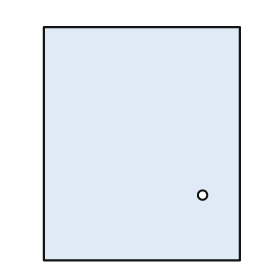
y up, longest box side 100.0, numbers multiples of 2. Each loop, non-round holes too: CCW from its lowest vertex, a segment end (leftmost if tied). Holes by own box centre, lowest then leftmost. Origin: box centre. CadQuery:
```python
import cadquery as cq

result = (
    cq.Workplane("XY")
    .moveTo(-42.0, -50.0)
    .lineTo(42.0, -50.0)
    .lineTo(42.0, 50.0)
    .lineTo(-42.0, 50.0)
    .close()
    .moveTo(26.0, -22.0)
    .circle(2.0)
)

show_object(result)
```